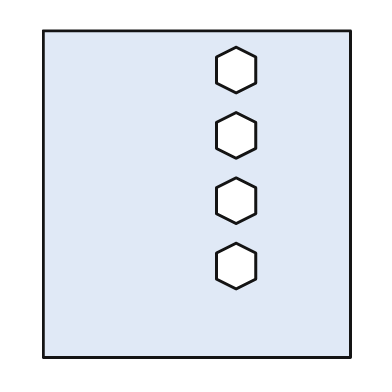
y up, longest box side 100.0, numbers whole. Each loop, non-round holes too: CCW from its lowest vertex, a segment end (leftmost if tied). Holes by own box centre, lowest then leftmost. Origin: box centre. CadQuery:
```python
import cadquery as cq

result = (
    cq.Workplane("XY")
    .moveTo(-47.0, -50.0)
    .lineTo(47.0, -50.0)
    .lineTo(47.0, 50.0)
    .lineTo(-47.0, 50.0)
    .close()
    .moveTo(12.0, -29.0)
    .lineTo(18.0, -26.0)
    .lineTo(18.0, -18.0)
    .lineTo(12.0, -15.0)
    .lineTo(6.0, -18.0)
    .lineTo(6.0, -26.0)
    .close()
    .moveTo(12.0, -9.0)
    .lineTo(18.0, -6.0)
    .lineTo(18.0, 2.0)
    .lineTo(12.0, 5.0)
    .lineTo(6.0, 2.0)
    .lineTo(6.0, -6.0)
    .close()
    .moveTo(12.0, 11.0)
    .lineTo(18.0, 14.0)
    .lineTo(18.0, 22.0)
    .lineTo(12.0, 25.0)
    .lineTo(6.0, 22.0)
    .lineTo(6.0, 14.0)
    .close()
    .moveTo(12.0, 31.0)
    .lineTo(18.0, 34.0)
    .lineTo(18.0, 42.0)
    .lineTo(12.0, 45.0)
    .lineTo(6.0, 42.0)
    .lineTo(6.0, 34.0)
    .close()
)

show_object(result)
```